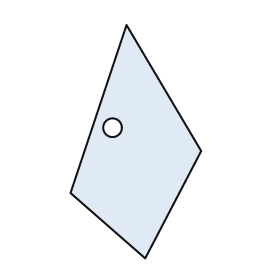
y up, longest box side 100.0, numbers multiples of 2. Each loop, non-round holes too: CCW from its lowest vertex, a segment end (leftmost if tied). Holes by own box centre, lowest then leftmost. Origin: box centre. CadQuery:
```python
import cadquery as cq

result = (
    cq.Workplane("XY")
    .moveTo(4.0, -50.0)
    .lineTo(28.0, -4.0)
    .lineTo(-4.0, 50.0)
    .lineTo(-28.0, -22.0)
    .close()
    .moveTo(-10.0, 6.0)
    .circle(4.0)
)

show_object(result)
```